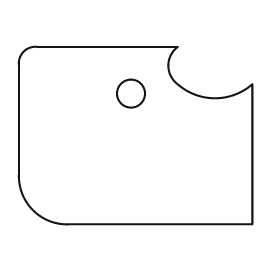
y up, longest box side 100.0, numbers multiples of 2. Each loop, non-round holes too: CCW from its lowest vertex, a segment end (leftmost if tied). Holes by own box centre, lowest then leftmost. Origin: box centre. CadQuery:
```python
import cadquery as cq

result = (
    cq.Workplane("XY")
    .moveTo(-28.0, -38.0)
    .lineTo(50.0, -38.0)
    .lineTo(50.0, 22.0)
    .threePointArc((34.0, 16.0), (18.0, 22.0))
    .threePointArc((14.0, 30.0), (18.0, 38.0))
    .lineTo(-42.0, 38.0)
    .threePointArc((-48.0, 36.0), (-50.0, 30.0))
    .lineTo(-50.0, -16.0)
    .threePointArc((-44.0, -32.0), (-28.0, -38.0))
    .close()
    .moveTo(-2.0, 18.0)
    .circle(6.0)
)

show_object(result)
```